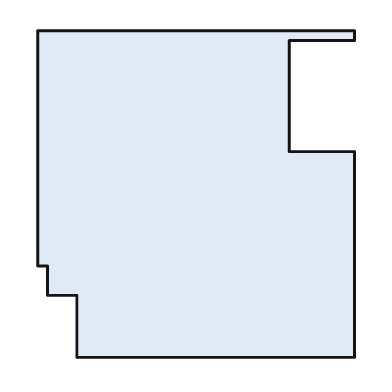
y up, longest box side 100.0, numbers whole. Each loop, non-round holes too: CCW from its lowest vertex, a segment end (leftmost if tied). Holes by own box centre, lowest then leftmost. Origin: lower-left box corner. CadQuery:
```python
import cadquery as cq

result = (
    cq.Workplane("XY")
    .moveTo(12.0, 0.0)
    .lineTo(97.0, 0.0)
    .lineTo(97.0, 63.0)
    .lineTo(77.0, 63.0)
    .lineTo(77.0, 97.0)
    .lineTo(97.0, 97.0)
    .lineTo(97.0, 100.0)
    .lineTo(0.0, 100.0)
    .lineTo(0.0, 28.0)
    .lineTo(3.0, 28.0)
    .lineTo(3.0, 19.0)
    .lineTo(12.0, 19.0)
    .close()
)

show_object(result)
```